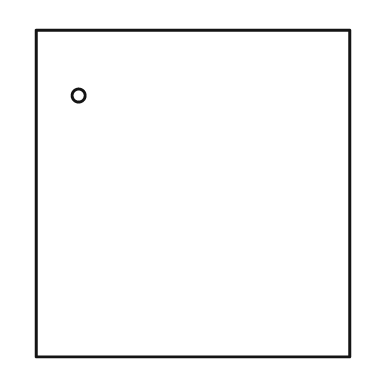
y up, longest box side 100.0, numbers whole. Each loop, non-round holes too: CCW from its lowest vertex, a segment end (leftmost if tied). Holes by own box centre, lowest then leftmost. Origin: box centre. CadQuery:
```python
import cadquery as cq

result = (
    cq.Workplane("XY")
    .moveTo(-48.0, -50.0)
    .lineTo(48.0, -50.0)
    .lineTo(48.0, 50.0)
    .lineTo(-48.0, 50.0)
    .close()
    .moveTo(-35.0, 30.0)
    .circle(2.0)
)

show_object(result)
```